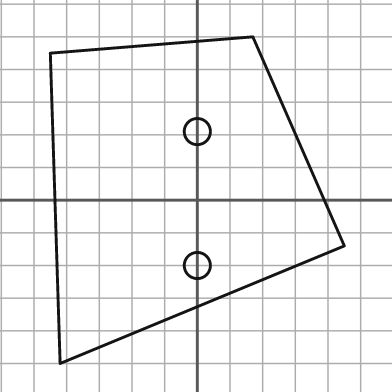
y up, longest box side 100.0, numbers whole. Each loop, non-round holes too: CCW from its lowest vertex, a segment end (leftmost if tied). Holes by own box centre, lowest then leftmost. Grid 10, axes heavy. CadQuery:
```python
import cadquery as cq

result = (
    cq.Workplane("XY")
    .moveTo(-42.0, -50.0)
    .lineTo(45.0, -14.0)
    .lineTo(17.0, 50.0)
    .lineTo(-45.0, 45.0)
    .close()
    .moveTo(0.0, -20.0)
    .circle(4.0)
    .moveTo(0.0, 21.0)
    .circle(4.0)
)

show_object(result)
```